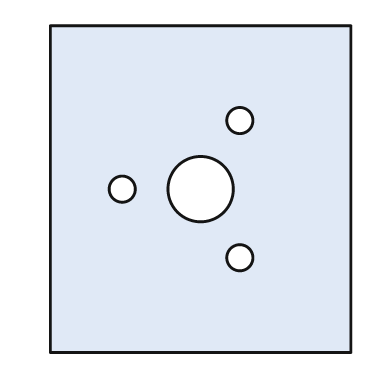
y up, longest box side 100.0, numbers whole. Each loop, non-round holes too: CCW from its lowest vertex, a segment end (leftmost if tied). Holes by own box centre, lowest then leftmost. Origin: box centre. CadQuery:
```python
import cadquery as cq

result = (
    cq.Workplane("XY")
    .moveTo(-46.0, -50.0)
    .lineTo(46.0, -50.0)
    .lineTo(46.0, 50.0)
    .lineTo(-46.0, 50.0)
    .close()
    .moveTo(12.0, -21.0)
    .circle(4.0)
    .moveTo(-24.0, 0.0)
    .circle(4.0)
    .moveTo(0.0, 0.0)
    .circle(10.0)
    .moveTo(12.0, 21.0)
    .circle(4.0)
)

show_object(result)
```